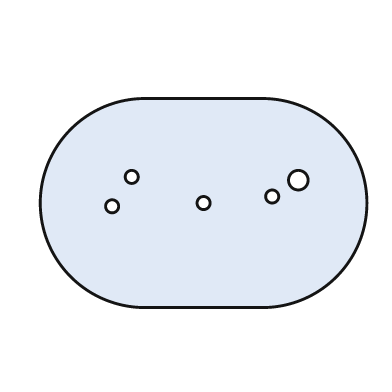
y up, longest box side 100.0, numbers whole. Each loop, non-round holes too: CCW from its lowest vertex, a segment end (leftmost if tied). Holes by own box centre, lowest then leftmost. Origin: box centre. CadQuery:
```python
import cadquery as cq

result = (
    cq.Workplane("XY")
    .moveTo(-18.0, -32.0)
    .lineTo(18.0, -32.0)
    .threePointArc((50.0, 0.0), (18.0, 32.0))
    .lineTo(-18.0, 32.0)
    .threePointArc((-50.0, 0.0), (-18.0, -32.0))
    .close()
    .moveTo(-28.0, -1.0)
    .circle(2.0)
    .moveTo(0.0, 0.0)
    .circle(2.0)
    .moveTo(21.0, 2.0)
    .circle(2.0)
    .moveTo(29.0, 7.0)
    .circle(3.0)
    .moveTo(-22.0, 8.0)
    .circle(2.0)
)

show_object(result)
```